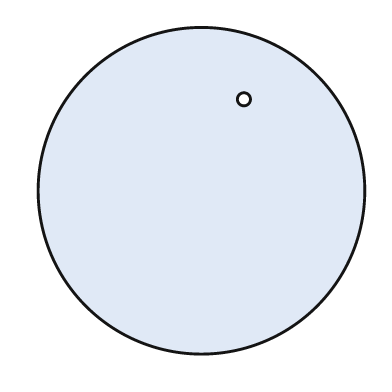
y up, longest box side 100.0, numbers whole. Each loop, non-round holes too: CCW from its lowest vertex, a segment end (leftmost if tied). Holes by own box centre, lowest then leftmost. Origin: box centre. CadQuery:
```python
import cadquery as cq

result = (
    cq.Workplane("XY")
    .moveTo(0.0, 0.0)
    .circle(50.0)
    .moveTo(13.0, 28.0)
    .circle(2.0)
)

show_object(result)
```